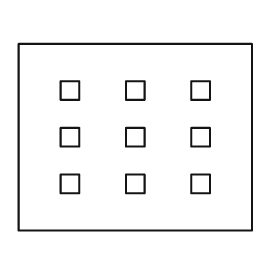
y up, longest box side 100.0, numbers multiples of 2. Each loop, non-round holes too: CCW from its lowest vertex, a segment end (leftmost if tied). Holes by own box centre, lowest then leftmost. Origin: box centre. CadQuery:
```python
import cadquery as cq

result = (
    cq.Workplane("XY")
    .moveTo(-50.0, -40.0)
    .lineTo(50.0, -40.0)
    .lineTo(50.0, 40.0)
    .lineTo(-50.0, 40.0)
    .close()
    .moveTo(-32.0, -24.0)
    .lineTo(-24.0, -24.0)
    .lineTo(-24.0, -16.0)
    .lineTo(-32.0, -16.0)
    .close()
    .moveTo(-4.0, -24.0)
    .lineTo(4.0, -24.0)
    .lineTo(4.0, -16.0)
    .lineTo(-4.0, -16.0)
    .close()
    .moveTo(24.0, -24.0)
    .lineTo(32.0, -24.0)
    .lineTo(32.0, -16.0)
    .lineTo(24.0, -16.0)
    .close()
    .moveTo(-32.0, -4.0)
    .lineTo(-24.0, -4.0)
    .lineTo(-24.0, 4.0)
    .lineTo(-32.0, 4.0)
    .close()
    .moveTo(-4.0, -4.0)
    .lineTo(4.0, -4.0)
    .lineTo(4.0, 4.0)
    .lineTo(-4.0, 4.0)
    .close()
    .moveTo(24.0, -4.0)
    .lineTo(32.0, -4.0)
    .lineTo(32.0, 4.0)
    .lineTo(24.0, 4.0)
    .close()
    .moveTo(-32.0, 16.0)
    .lineTo(-24.0, 16.0)
    .lineTo(-24.0, 24.0)
    .lineTo(-32.0, 24.0)
    .close()
    .moveTo(-4.0, 16.0)
    .lineTo(4.0, 16.0)
    .lineTo(4.0, 24.0)
    .lineTo(-4.0, 24.0)
    .close()
    .moveTo(24.0, 16.0)
    .lineTo(32.0, 16.0)
    .lineTo(32.0, 24.0)
    .lineTo(24.0, 24.0)
    .close()
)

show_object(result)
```